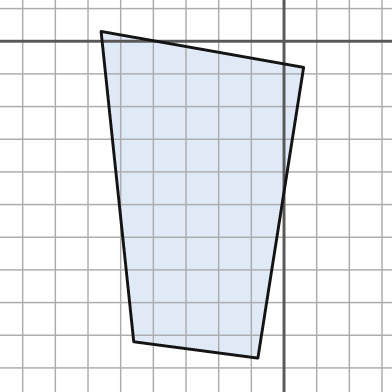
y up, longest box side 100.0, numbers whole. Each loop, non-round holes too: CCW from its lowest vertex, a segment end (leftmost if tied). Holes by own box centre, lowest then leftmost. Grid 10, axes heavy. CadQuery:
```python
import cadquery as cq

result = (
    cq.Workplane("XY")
    .moveTo(-8.0, -97.0)
    .lineTo(6.0, -8.0)
    .lineTo(-56.0, 3.0)
    .lineTo(-46.0, -92.0)
    .close()
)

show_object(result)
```